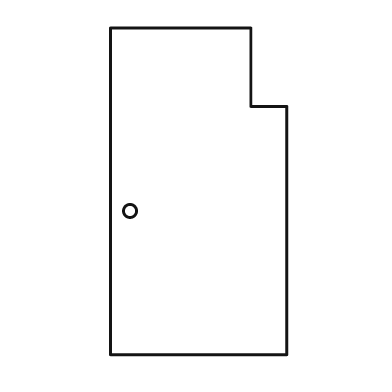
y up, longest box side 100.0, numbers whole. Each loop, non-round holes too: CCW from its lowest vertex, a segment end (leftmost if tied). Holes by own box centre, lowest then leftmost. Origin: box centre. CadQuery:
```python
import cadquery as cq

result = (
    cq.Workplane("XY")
    .moveTo(-27.0, -50.0)
    .lineTo(27.0, -50.0)
    .lineTo(27.0, 26.0)
    .lineTo(16.0, 26.0)
    .lineTo(16.0, 50.0)
    .lineTo(-27.0, 50.0)
    .close()
    .moveTo(-21.0, -6.0)
    .circle(2.0)
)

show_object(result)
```